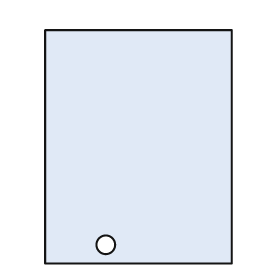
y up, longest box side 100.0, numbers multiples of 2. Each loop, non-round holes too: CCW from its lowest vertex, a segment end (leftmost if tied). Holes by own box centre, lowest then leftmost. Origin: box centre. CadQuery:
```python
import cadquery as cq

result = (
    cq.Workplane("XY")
    .moveTo(-40.0, -50.0)
    .lineTo(40.0, -50.0)
    .lineTo(40.0, 50.0)
    .lineTo(-40.0, 50.0)
    .close()
    .moveTo(-14.0, -42.0)
    .circle(4.0)
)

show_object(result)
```